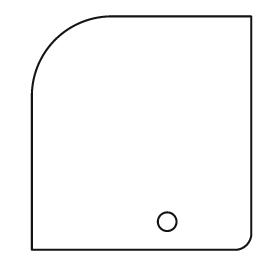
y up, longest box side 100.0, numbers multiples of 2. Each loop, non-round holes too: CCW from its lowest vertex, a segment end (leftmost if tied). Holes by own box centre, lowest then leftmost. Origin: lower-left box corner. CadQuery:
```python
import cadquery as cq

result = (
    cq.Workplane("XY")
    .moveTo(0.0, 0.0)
    .lineTo(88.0, 0.0)
    .threePointArc((92.0, 2.0), (94.0, 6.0))
    .lineTo(94.0, 100.0)
    .lineTo(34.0, 100.0)
    .threePointArc((10.0, 90.0), (0.0, 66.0))
    .close()
    .moveTo(58.0, 12.0)
    .circle(4.0)
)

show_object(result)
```